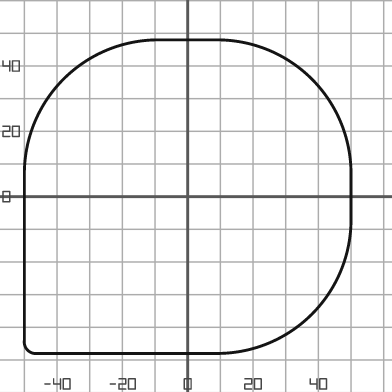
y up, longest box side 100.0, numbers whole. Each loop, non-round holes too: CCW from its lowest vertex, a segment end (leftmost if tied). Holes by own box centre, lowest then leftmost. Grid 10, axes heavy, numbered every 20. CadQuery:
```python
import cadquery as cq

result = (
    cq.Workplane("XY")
    .moveTo(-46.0, -48.0)
    .lineTo(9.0, -48.0)
    .threePointArc((38.0, -36.0), (50.0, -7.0))
    .lineTo(50.0, 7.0)
    .threePointArc((38.0, 36.0), (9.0, 48.0))
    .lineTo(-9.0, 48.0)
    .threePointArc((-38.0, 36.0), (-50.0, 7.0))
    .lineTo(-50.0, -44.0)
    .threePointArc((-49.0, -47.0), (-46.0, -48.0))
    .close()
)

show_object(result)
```